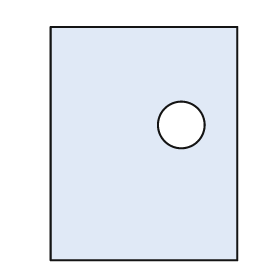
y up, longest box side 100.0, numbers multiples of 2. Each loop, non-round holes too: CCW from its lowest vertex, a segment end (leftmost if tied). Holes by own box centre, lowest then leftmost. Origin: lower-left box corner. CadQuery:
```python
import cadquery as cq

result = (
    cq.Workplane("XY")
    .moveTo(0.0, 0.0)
    .lineTo(80.0, 0.0)
    .lineTo(80.0, 100.0)
    .lineTo(0.0, 100.0)
    .close()
    .moveTo(56.0, 58.0)
    .circle(10.0)
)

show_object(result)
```